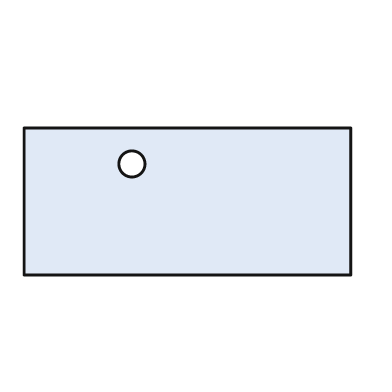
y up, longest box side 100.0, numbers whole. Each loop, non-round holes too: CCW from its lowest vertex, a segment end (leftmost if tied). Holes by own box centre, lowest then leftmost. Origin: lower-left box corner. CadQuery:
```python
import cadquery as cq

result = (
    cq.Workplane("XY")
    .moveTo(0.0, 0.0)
    .lineTo(100.0, 0.0)
    .lineTo(100.0, 45.0)
    .lineTo(0.0, 45.0)
    .close()
    .moveTo(33.0, 34.0)
    .circle(4.0)
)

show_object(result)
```